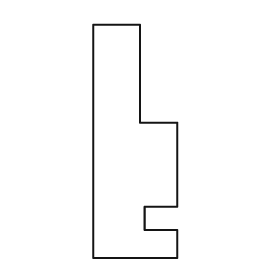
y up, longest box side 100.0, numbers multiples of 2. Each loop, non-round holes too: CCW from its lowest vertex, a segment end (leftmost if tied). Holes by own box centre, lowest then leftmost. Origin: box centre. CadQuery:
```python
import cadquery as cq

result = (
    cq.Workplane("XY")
    .moveTo(-18.0, -50.0)
    .lineTo(18.0, -50.0)
    .lineTo(18.0, -38.0)
    .lineTo(4.0, -38.0)
    .lineTo(4.0, -28.0)
    .lineTo(18.0, -28.0)
    .lineTo(18.0, 8.0)
    .lineTo(2.0, 8.0)
    .lineTo(2.0, 50.0)
    .lineTo(-18.0, 50.0)
    .close()
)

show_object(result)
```